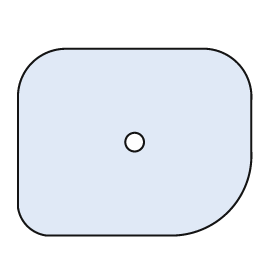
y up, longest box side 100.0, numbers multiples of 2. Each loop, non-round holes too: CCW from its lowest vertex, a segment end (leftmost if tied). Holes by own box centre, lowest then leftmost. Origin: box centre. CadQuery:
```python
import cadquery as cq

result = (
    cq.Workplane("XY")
    .moveTo(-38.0, -40.0)
    .lineTo(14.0, -40.0)
    .threePointArc((40.0, -30.0), (50.0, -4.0))
    .lineTo(50.0, 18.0)
    .threePointArc((44.0, 34.0), (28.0, 40.0))
    .lineTo(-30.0, 40.0)
    .threePointArc((-44.0, 34.0), (-50.0, 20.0))
    .lineTo(-50.0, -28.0)
    .threePointArc((-46.0, -36.0), (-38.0, -40.0))
    .close()
    .moveTo(0.0, 0.0)
    .circle(4.0)
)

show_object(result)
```